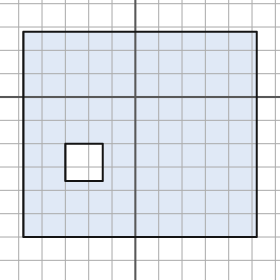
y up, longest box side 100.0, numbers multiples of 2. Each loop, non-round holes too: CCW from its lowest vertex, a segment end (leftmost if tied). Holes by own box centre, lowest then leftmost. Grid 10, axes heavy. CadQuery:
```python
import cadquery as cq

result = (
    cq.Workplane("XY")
    .moveTo(-48.0, -60.0)
    .lineTo(52.0, -60.0)
    .lineTo(52.0, 28.0)
    .lineTo(-48.0, 28.0)
    .close()
    .moveTo(-30.0, -36.0)
    .lineTo(-14.0, -36.0)
    .lineTo(-14.0, -20.0)
    .lineTo(-30.0, -20.0)
    .close()
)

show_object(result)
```